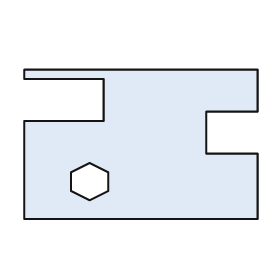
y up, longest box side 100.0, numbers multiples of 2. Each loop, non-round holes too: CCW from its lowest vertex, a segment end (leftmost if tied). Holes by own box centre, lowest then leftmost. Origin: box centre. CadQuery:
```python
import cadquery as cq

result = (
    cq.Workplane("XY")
    .moveTo(-50.0, -32.0)
    .lineTo(50.0, -32.0)
    .lineTo(50.0, -4.0)
    .lineTo(28.0, -4.0)
    .lineTo(28.0, 14.0)
    .lineTo(50.0, 14.0)
    .lineTo(50.0, 32.0)
    .lineTo(-50.0, 32.0)
    .lineTo(-50.0, 28.0)
    .lineTo(-16.0, 28.0)
    .lineTo(-16.0, 10.0)
    .lineTo(-50.0, 10.0)
    .close()
    .moveTo(-22.0, -24.0)
    .lineTo(-14.0, -20.0)
    .lineTo(-14.0, -12.0)
    .lineTo(-22.0, -8.0)
    .lineTo(-30.0, -12.0)
    .lineTo(-30.0, -20.0)
    .close()
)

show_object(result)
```